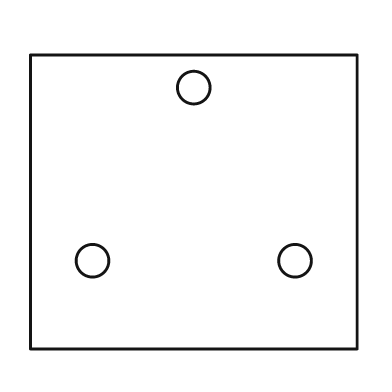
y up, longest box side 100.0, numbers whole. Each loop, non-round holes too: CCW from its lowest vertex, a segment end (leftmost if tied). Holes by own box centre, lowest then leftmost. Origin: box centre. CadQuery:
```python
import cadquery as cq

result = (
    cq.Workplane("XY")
    .moveTo(-50.0, -45.0)
    .lineTo(50.0, -45.0)
    .lineTo(50.0, 45.0)
    .lineTo(-50.0, 45.0)
    .close()
    .moveTo(-31.0, -18.0)
    .circle(5.0)
    .moveTo(31.0, -18.0)
    .circle(5.0)
    .moveTo(0.0, 35.0)
    .circle(5.0)
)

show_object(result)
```